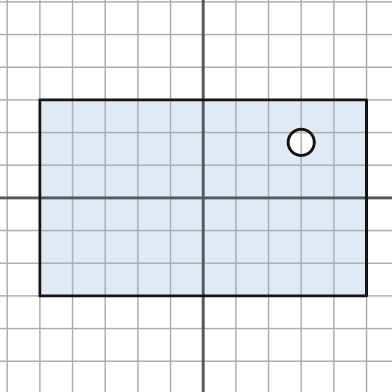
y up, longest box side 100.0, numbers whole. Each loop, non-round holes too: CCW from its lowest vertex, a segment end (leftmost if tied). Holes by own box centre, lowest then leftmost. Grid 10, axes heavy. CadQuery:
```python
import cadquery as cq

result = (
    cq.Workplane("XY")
    .moveTo(-50.0, -30.0)
    .lineTo(50.0, -30.0)
    .lineTo(50.0, 30.0)
    .lineTo(-50.0, 30.0)
    .close()
    .moveTo(30.0, 17.0)
    .circle(4.0)
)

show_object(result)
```